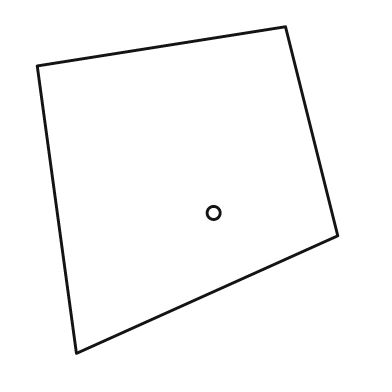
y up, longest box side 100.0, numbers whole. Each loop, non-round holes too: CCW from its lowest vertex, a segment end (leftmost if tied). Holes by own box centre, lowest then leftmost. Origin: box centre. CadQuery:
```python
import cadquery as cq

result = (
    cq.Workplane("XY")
    .moveTo(-34.0, -50.0)
    .lineTo(46.0, -14.0)
    .lineTo(30.0, 50.0)
    .lineTo(-46.0, 38.0)
    .close()
    .moveTo(8.0, -7.0)
    .circle(2.0)
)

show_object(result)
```